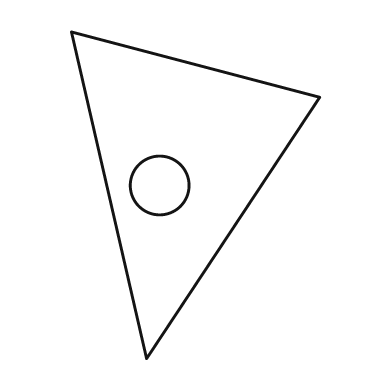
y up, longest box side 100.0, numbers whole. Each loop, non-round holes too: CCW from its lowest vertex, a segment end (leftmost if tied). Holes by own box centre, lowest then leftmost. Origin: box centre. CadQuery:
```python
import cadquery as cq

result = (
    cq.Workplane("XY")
    .moveTo(-15.0, -50.0)
    .lineTo(38.0, 30.0)
    .lineTo(-38.0, 50.0)
    .close()
    .moveTo(-11.0, 3.0)
    .circle(9.0)
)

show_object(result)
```